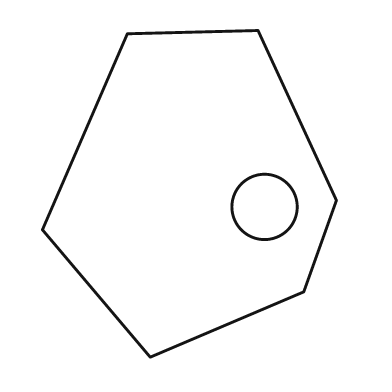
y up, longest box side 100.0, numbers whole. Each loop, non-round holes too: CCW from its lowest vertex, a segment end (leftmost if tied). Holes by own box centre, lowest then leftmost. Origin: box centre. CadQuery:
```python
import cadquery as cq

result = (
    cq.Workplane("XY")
    .moveTo(-12.0, -50.0)
    .lineTo(35.0, -30.0)
    .lineTo(45.0, -2.0)
    .lineTo(21.0, 50.0)
    .lineTo(-19.0, 49.0)
    .lineTo(-45.0, -11.0)
    .close()
    .moveTo(23.0, -4.0)
    .circle(10.0)
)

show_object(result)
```